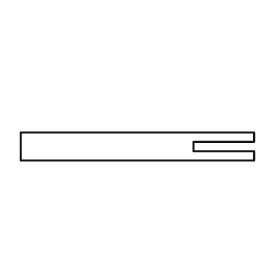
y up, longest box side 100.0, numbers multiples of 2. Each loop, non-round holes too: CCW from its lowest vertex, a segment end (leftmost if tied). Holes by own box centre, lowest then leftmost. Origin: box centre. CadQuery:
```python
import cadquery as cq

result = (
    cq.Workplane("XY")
    .moveTo(-50.0, -6.0)
    .lineTo(50.0, -6.0)
    .lineTo(50.0, -2.0)
    .lineTo(24.0, -2.0)
    .lineTo(24.0, 2.0)
    .lineTo(50.0, 2.0)
    .lineTo(50.0, 6.0)
    .lineTo(-50.0, 6.0)
    .close()
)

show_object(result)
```